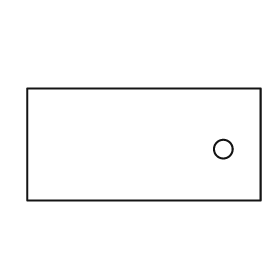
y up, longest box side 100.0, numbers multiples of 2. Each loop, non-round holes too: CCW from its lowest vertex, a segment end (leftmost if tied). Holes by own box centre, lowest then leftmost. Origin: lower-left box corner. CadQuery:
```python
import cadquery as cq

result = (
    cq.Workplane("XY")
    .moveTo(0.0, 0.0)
    .lineTo(100.0, 0.0)
    .lineTo(100.0, 48.0)
    .lineTo(0.0, 48.0)
    .close()
    .moveTo(84.0, 22.0)
    .circle(4.0)
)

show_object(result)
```